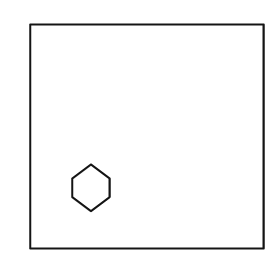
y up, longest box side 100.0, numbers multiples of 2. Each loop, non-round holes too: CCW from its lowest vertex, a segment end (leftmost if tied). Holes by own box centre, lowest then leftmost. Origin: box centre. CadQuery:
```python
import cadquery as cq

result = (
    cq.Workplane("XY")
    .moveTo(-50.0, -48.0)
    .lineTo(50.0, -48.0)
    .lineTo(50.0, 48.0)
    .lineTo(-50.0, 48.0)
    .close()
    .moveTo(-24.0, -32.0)
    .lineTo(-16.0, -26.0)
    .lineTo(-16.0, -18.0)
    .lineTo(-24.0, -12.0)
    .lineTo(-32.0, -18.0)
    .lineTo(-32.0, -26.0)
    .close()
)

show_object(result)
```